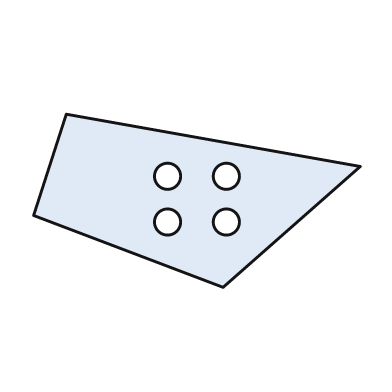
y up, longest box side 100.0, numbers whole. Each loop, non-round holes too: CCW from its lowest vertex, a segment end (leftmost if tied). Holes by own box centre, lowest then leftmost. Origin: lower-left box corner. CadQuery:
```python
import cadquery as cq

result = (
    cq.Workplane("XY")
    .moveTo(58.0, 0.0)
    .lineTo(100.0, 37.0)
    .lineTo(10.0, 53.0)
    .lineTo(0.0, 22.0)
    .close()
    .moveTo(41.0, 20.0)
    .circle(4.0)
    .moveTo(59.0, 20.0)
    .circle(4.0)
    .moveTo(41.0, 34.0)
    .circle(4.0)
    .moveTo(59.0, 34.0)
    .circle(4.0)
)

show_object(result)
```